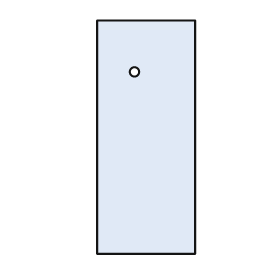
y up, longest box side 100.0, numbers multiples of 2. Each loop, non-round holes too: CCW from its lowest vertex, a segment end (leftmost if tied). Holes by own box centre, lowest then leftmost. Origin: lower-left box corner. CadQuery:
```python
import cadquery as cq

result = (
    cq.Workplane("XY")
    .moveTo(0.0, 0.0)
    .lineTo(42.0, 0.0)
    .lineTo(42.0, 100.0)
    .lineTo(0.0, 100.0)
    .close()
    .moveTo(16.0, 78.0)
    .circle(2.0)
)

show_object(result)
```